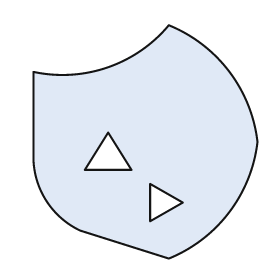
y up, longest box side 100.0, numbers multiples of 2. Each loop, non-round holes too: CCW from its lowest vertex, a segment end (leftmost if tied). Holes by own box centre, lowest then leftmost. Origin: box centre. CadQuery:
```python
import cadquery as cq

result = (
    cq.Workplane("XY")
    .moveTo(10.0, -50.0)
    .threePointArc((36.0, -30.0), (48.0, 0.0))
    .threePointArc((36.0, 30.0), (10.0, 50.0))
    .threePointArc((-16.0, 32.0), (-48.0, 30.0))
    .lineTo(-48.0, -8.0)
    .threePointArc((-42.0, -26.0), (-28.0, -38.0))
    .close()
    .moveTo(2.0, -34.0)
    .lineTo(16.0, -26.0)
    .lineTo(2.0, -18.0)
    .close()
    .moveTo(-26.0, -12.0)
    .lineTo(-6.0, -12.0)
    .lineTo(-16.0, 4.0)
    .close()
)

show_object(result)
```